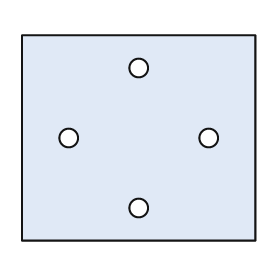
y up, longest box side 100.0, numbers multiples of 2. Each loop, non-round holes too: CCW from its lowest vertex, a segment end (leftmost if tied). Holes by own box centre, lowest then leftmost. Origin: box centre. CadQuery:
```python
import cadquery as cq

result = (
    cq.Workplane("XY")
    .moveTo(-50.0, -44.0)
    .lineTo(50.0, -44.0)
    .lineTo(50.0, 44.0)
    .lineTo(-50.0, 44.0)
    .close()
    .moveTo(0.0, -30.0)
    .circle(4.0)
    .moveTo(-30.0, 0.0)
    .circle(4.0)
    .moveTo(30.0, 0.0)
    .circle(4.0)
    .moveTo(0.0, 30.0)
    .circle(4.0)
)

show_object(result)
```